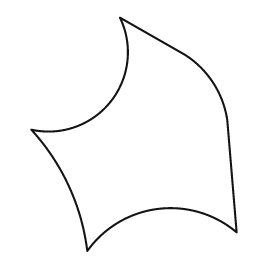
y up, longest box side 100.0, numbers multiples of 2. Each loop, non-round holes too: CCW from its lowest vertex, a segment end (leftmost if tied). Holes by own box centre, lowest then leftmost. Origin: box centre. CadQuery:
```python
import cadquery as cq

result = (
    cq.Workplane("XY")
    .moveTo(-20.0, -50.0)
    .threePointArc((10.0, -32.0), (44.0, -42.0))
    .lineTo(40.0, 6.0)
    .threePointArc((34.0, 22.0), (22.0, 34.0))
    .lineTo(-6.0, 50.0)
    .threePointArc((-10.0, 14.0), (-44.0, 2.0))
    .threePointArc((-28.0, -22.0), (-20.0, -50.0))
    .close()
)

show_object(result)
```